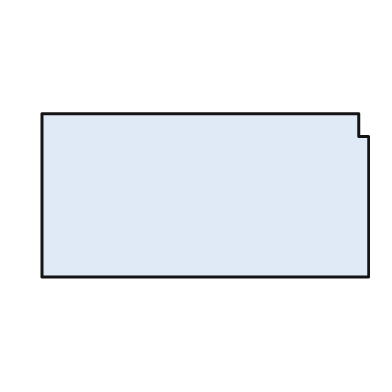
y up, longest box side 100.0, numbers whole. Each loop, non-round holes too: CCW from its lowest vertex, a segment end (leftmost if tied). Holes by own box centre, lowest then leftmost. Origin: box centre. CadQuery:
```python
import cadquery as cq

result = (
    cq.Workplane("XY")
    .moveTo(-50.0, -25.0)
    .lineTo(50.0, -25.0)
    .lineTo(50.0, 18.0)
    .lineTo(47.0, 18.0)
    .lineTo(47.0, 25.0)
    .lineTo(-50.0, 25.0)
    .close()
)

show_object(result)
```